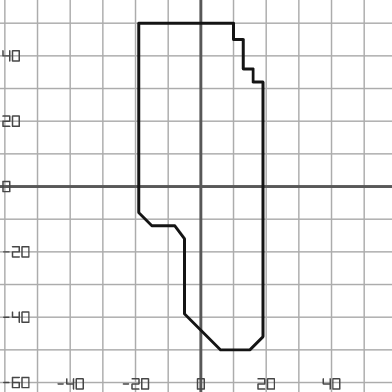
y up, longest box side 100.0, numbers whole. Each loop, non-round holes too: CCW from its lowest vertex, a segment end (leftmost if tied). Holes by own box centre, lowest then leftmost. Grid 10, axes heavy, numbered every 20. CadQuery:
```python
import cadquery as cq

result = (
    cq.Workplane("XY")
    .moveTo(6.0, -50.0)
    .lineTo(15.0, -50.0)
    .lineTo(19.0, -46.0)
    .lineTo(19.0, 32.0)
    .lineTo(16.0, 32.0)
    .lineTo(16.0, 36.0)
    .lineTo(13.0, 36.0)
    .lineTo(13.0, 45.0)
    .lineTo(10.0, 45.0)
    .lineTo(10.0, 50.0)
    .lineTo(-19.0, 50.0)
    .lineTo(-19.0, -8.0)
    .lineTo(-15.0, -12.0)
    .lineTo(-8.0, -12.0)
    .lineTo(-5.0, -16.0)
    .lineTo(-5.0, -39.0)
    .close()
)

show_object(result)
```